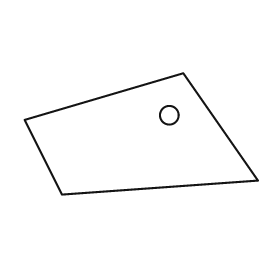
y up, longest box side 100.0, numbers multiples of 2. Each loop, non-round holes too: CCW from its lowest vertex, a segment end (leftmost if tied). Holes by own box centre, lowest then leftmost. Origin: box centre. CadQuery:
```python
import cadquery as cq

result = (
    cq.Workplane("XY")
    .moveTo(-34.0, -26.0)
    .lineTo(50.0, -20.0)
    .lineTo(18.0, 26.0)
    .lineTo(-50.0, 6.0)
    .close()
    .moveTo(12.0, 8.0)
    .circle(4.0)
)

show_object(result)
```